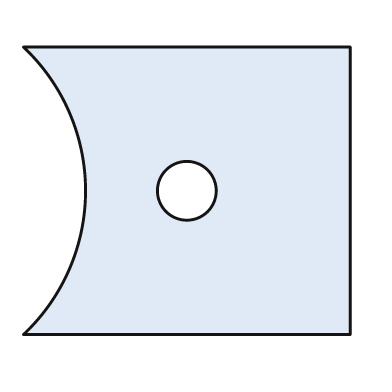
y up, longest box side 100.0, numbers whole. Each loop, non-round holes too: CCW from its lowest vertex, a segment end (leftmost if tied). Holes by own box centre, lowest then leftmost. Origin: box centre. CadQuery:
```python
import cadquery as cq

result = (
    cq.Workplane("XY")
    .moveTo(-50.0, -44.0)
    .lineTo(50.0, -44.0)
    .lineTo(50.0, 44.0)
    .lineTo(-50.0, 44.0)
    .threePointArc((-31.0, 0.0), (-50.0, -44.0))
    .close()
    .moveTo(0.0, 0.0)
    .circle(9.0)
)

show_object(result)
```